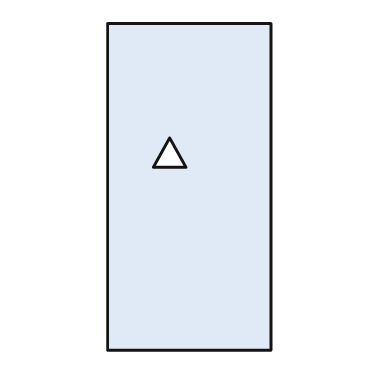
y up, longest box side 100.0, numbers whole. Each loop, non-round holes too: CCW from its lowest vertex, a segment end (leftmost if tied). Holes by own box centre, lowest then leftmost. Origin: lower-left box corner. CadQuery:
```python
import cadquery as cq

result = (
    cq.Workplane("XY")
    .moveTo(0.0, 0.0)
    .lineTo(50.0, 0.0)
    .lineTo(50.0, 100.0)
    .lineTo(0.0, 100.0)
    .close()
    .moveTo(14.0, 56.0)
    .lineTo(24.0, 56.0)
    .lineTo(19.0, 65.0)
    .close()
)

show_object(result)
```